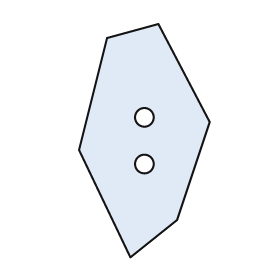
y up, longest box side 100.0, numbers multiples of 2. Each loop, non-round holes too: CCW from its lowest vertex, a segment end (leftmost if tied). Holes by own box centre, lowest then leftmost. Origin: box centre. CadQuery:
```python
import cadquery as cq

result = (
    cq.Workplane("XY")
    .moveTo(-6.0, -50.0)
    .lineTo(14.0, -34.0)
    .lineTo(28.0, 8.0)
    .lineTo(6.0, 50.0)
    .lineTo(-16.0, 44.0)
    .lineTo(-28.0, -4.0)
    .close()
    .moveTo(0.0, -10.0)
    .circle(4.0)
    .moveTo(0.0, 10.0)
    .circle(4.0)
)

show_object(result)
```